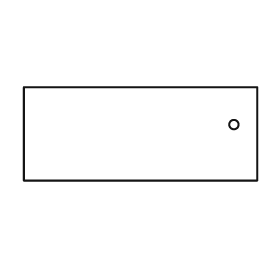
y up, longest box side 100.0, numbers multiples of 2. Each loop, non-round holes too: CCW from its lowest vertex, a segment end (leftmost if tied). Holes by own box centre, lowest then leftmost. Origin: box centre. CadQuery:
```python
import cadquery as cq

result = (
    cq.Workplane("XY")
    .moveTo(-50.0, -20.0)
    .lineTo(50.0, -20.0)
    .lineTo(50.0, 20.0)
    .lineTo(-50.0, 20.0)
    .close()
    .moveTo(40.0, 4.0)
    .circle(2.0)
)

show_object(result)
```